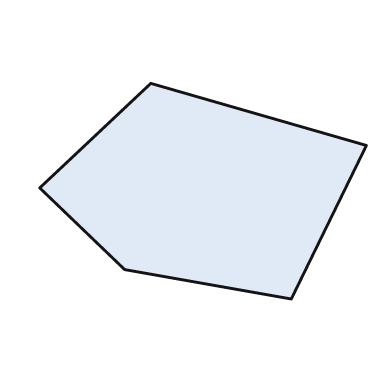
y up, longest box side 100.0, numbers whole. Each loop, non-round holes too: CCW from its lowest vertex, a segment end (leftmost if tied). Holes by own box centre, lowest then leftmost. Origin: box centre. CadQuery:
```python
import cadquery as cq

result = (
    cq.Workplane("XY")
    .moveTo(27.0, -33.0)
    .lineTo(50.0, 14.0)
    .lineTo(-16.0, 33.0)
    .lineTo(-50.0, 1.0)
    .lineTo(-24.0, -24.0)
    .close()
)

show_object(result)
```